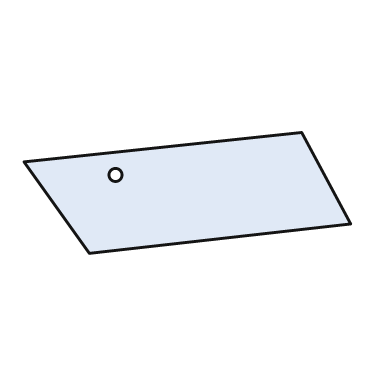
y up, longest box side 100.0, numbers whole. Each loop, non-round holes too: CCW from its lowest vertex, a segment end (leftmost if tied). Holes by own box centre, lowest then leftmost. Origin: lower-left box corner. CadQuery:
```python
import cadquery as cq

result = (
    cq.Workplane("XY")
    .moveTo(20.0, 0.0)
    .lineTo(100.0, 9.0)
    .lineTo(85.0, 37.0)
    .lineTo(0.0, 28.0)
    .close()
    .moveTo(28.0, 24.0)
    .circle(2.0)
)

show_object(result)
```